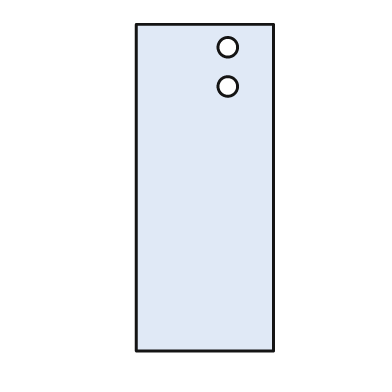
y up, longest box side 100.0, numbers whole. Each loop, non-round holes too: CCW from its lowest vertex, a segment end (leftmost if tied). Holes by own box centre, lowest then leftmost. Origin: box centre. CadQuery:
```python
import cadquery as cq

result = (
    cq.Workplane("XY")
    .moveTo(-21.0, -50.0)
    .lineTo(21.0, -50.0)
    .lineTo(21.0, 50.0)
    .lineTo(-21.0, 50.0)
    .close()
    .moveTo(7.0, 31.0)
    .circle(3.0)
    .moveTo(7.0, 43.0)
    .circle(3.0)
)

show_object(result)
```